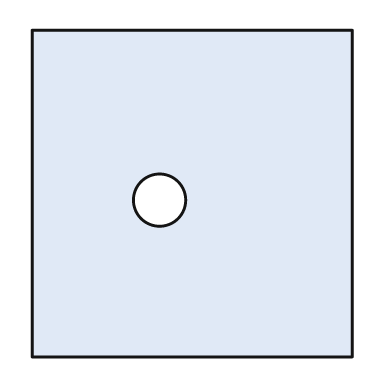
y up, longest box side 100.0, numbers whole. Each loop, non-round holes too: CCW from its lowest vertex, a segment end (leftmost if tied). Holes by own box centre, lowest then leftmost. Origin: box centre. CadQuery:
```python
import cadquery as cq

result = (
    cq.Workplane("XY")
    .moveTo(-49.0, -50.0)
    .lineTo(49.0, -50.0)
    .lineTo(49.0, 50.0)
    .lineTo(-49.0, 50.0)
    .close()
    .moveTo(-10.0, -2.0)
    .circle(8.0)
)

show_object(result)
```